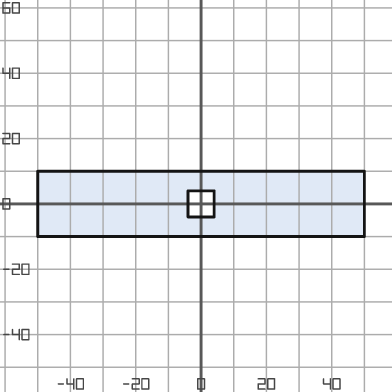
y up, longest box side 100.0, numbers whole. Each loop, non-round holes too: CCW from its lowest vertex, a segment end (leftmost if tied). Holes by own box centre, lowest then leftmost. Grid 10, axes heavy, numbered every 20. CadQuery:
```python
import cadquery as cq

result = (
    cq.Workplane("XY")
    .moveTo(-50.0, -10.0)
    .lineTo(50.0, -10.0)
    .lineTo(50.0, 10.0)
    .lineTo(-50.0, 10.0)
    .close()
    .moveTo(-4.0, -4.0)
    .lineTo(4.0, -4.0)
    .lineTo(4.0, 4.0)
    .lineTo(-4.0, 4.0)
    .close()
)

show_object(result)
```